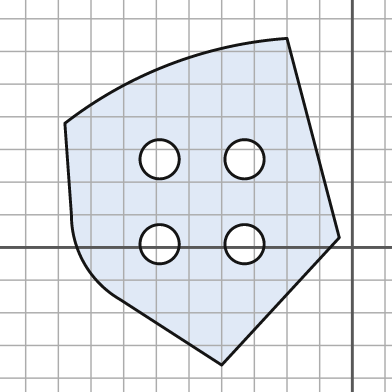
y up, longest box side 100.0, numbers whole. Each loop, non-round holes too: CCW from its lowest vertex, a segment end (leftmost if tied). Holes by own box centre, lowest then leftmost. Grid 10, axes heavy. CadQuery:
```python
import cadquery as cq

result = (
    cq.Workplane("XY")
    .moveTo(-40.0, -36.0)
    .lineTo(-4.0, 3.0)
    .lineTo(-20.0, 64.0)
    .threePointArc((-56.0, 56.0), (-88.0, 38.0))
    .lineTo(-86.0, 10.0)
    .threePointArc((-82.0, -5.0), (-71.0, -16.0))
    .close()
    .moveTo(-59.0, 1.0)
    .circle(6.0)
    .moveTo(-33.0, 1.0)
    .circle(6.0)
    .moveTo(-59.0, 27.0)
    .circle(6.0)
    .moveTo(-33.0, 27.0)
    .circle(6.0)
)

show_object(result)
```